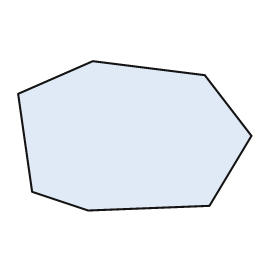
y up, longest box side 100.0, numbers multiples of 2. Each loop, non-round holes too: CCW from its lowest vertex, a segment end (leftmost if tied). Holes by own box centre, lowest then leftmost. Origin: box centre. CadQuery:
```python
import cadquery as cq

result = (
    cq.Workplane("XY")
    .moveTo(-20.0, -32.0)
    .lineTo(32.0, -30.0)
    .lineTo(50.0, 0.0)
    .lineTo(30.0, 26.0)
    .lineTo(-18.0, 32.0)
    .lineTo(-50.0, 18.0)
    .lineTo(-44.0, -24.0)
    .close()
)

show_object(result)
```